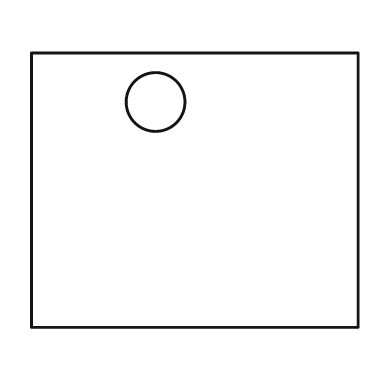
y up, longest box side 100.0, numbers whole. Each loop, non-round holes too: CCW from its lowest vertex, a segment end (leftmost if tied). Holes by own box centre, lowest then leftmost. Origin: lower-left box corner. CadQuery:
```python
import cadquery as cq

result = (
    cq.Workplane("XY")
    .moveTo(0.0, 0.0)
    .lineTo(100.0, 0.0)
    .lineTo(100.0, 84.0)
    .lineTo(0.0, 84.0)
    .close()
    .moveTo(38.0, 69.0)
    .circle(9.0)
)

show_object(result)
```